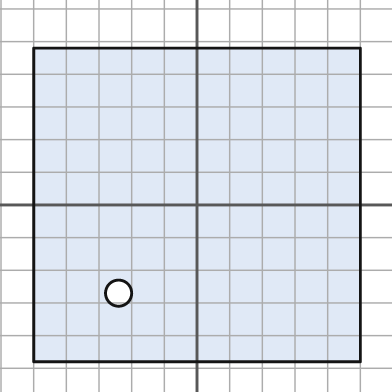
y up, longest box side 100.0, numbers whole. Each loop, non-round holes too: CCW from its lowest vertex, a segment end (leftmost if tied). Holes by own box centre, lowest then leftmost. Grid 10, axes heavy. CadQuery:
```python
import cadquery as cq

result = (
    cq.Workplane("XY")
    .moveTo(-50.0, -48.0)
    .lineTo(50.0, -48.0)
    .lineTo(50.0, 48.0)
    .lineTo(-50.0, 48.0)
    .close()
    .moveTo(-24.0, -27.0)
    .circle(4.0)
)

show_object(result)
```